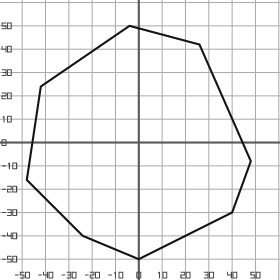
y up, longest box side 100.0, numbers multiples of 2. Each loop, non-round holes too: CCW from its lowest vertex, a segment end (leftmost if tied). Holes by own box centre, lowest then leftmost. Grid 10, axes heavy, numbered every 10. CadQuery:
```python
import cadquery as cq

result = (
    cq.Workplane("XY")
    .moveTo(0.0, -50.0)
    .lineTo(40.0, -30.0)
    .lineTo(48.0, -8.0)
    .lineTo(26.0, 42.0)
    .lineTo(-4.0, 50.0)
    .lineTo(-42.0, 24.0)
    .lineTo(-48.0, -16.0)
    .lineTo(-24.0, -40.0)
    .close()
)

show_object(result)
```